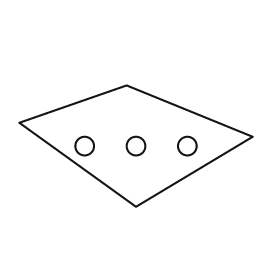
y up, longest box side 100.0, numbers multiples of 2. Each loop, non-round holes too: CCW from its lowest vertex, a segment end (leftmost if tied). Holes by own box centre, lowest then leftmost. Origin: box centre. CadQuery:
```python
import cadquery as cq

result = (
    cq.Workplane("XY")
    .moveTo(0.0, -26.0)
    .lineTo(50.0, 4.0)
    .lineTo(-4.0, 26.0)
    .lineTo(-50.0, 10.0)
    .close()
    .moveTo(-22.0, 0.0)
    .circle(4.0)
    .moveTo(0.0, 0.0)
    .circle(4.0)
    .moveTo(22.0, 0.0)
    .circle(4.0)
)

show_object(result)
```